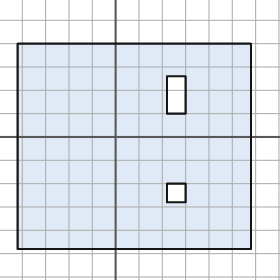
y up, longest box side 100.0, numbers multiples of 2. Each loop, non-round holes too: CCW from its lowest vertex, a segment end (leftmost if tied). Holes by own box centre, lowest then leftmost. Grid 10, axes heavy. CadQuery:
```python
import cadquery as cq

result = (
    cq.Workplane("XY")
    .moveTo(-42.0, -48.0)
    .lineTo(58.0, -48.0)
    .lineTo(58.0, 40.0)
    .lineTo(-42.0, 40.0)
    .close()
    .moveTo(22.0, -28.0)
    .lineTo(30.0, -28.0)
    .lineTo(30.0, -20.0)
    .lineTo(22.0, -20.0)
    .close()
    .moveTo(22.0, 10.0)
    .lineTo(30.0, 10.0)
    .lineTo(30.0, 26.0)
    .lineTo(22.0, 26.0)
    .close()
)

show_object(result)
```